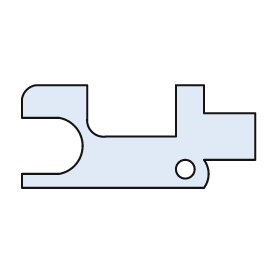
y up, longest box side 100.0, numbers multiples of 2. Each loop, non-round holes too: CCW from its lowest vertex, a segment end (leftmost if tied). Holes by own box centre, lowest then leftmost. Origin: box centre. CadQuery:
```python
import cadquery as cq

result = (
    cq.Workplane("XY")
    .moveTo(-50.0, -22.0)
    .lineTo(28.0, -22.0)
    .threePointArc((30.0, -16.0), (28.0, -10.0))
    .lineTo(50.0, -10.0)
    .lineTo(50.0, 10.0)
    .lineTo(28.0, 10.0)
    .lineTo(28.0, 22.0)
    .lineTo(16.0, 22.0)
    .lineTo(16.0, 0.0)
    .lineTo(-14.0, 0.0)
    .threePointArc((-20.0, 2.0), (-22.0, 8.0))
    .lineTo(-22.0, 22.0)
    .lineTo(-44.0, 22.0)
    .threePointArc((-48.0, 20.0), (-50.0, 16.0))
    .lineTo(-50.0, 8.0)
    .lineTo(-34.0, 8.0)
    .threePointArc((-24.0, -4.0), (-34.0, -16.0))
    .lineTo(-50.0, -16.0)
    .close()
    .moveTo(20.0, -14.0)
    .circle(4.0)
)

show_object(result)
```